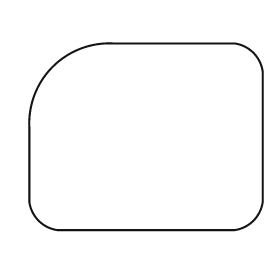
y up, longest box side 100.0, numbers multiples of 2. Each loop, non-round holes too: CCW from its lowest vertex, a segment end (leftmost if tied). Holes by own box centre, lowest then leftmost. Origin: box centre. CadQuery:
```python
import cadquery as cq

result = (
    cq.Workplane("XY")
    .moveTo(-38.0, -40.0)
    .lineTo(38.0, -40.0)
    .threePointArc((46.0, -36.0), (50.0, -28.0))
    .lineTo(50.0, 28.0)
    .threePointArc((46.0, 36.0), (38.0, 40.0))
    .lineTo(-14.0, 40.0)
    .threePointArc((-40.0, 30.0), (-50.0, 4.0))
    .lineTo(-50.0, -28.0)
    .threePointArc((-46.0, -36.0), (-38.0, -40.0))
    .close()
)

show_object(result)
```